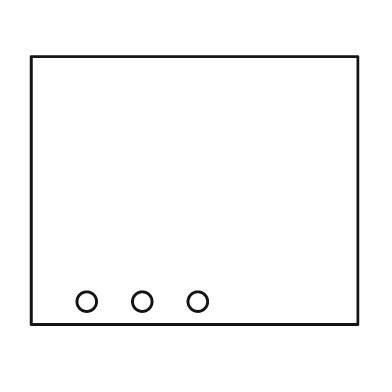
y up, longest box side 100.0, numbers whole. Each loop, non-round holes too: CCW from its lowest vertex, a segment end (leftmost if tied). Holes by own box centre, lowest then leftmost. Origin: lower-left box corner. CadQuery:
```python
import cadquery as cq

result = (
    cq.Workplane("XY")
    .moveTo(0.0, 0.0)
    .lineTo(100.0, 0.0)
    .lineTo(100.0, 82.0)
    .lineTo(0.0, 82.0)
    .close()
    .moveTo(17.0, 7.0)
    .circle(3.0)
    .moveTo(34.0, 7.0)
    .circle(3.0)
    .moveTo(51.0, 7.0)
    .circle(3.0)
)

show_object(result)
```